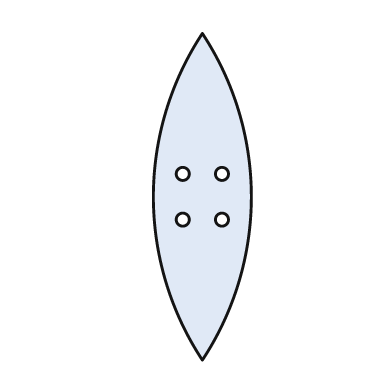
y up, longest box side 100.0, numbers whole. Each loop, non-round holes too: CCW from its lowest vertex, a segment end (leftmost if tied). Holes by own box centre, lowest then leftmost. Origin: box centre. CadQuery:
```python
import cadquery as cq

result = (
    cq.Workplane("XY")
    .moveTo(0.0, -50.0)
    .threePointArc((15.0, 0.0), (0.0, 50.0))
    .threePointArc((-15.0, 0.0), (0.0, -50.0))
    .close()
    .moveTo(-6.0, -7.0)
    .circle(2.0)
    .moveTo(6.0, -7.0)
    .circle(2.0)
    .moveTo(-6.0, 7.0)
    .circle(2.0)
    .moveTo(6.0, 7.0)
    .circle(2.0)
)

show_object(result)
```